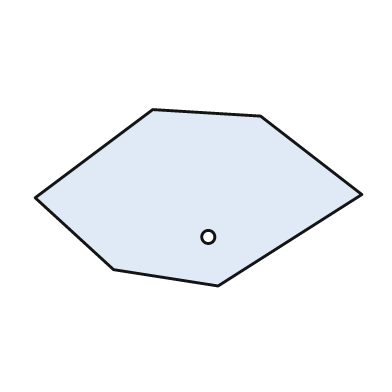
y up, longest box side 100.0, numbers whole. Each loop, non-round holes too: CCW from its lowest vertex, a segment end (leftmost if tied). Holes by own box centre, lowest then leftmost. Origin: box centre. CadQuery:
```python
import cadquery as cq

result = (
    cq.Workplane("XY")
    .moveTo(6.0, -27.0)
    .lineTo(50.0, 1.0)
    .lineTo(19.0, 25.0)
    .lineTo(-14.0, 27.0)
    .lineTo(-50.0, 0.0)
    .lineTo(-26.0, -22.0)
    .close()
    .moveTo(3.0, -12.0)
    .circle(2.0)
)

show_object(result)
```